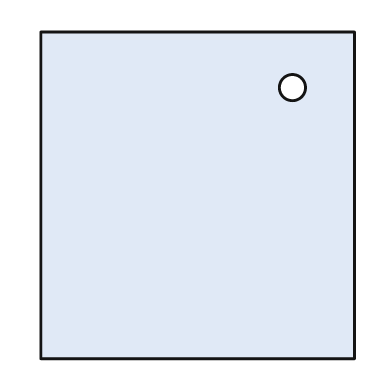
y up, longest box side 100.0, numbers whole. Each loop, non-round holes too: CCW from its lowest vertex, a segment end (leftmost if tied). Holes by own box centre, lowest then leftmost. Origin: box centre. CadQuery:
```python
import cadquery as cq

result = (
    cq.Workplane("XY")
    .moveTo(-48.0, -50.0)
    .lineTo(48.0, -50.0)
    .lineTo(48.0, 50.0)
    .lineTo(-48.0, 50.0)
    .close()
    .moveTo(29.0, 33.0)
    .circle(4.0)
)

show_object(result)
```